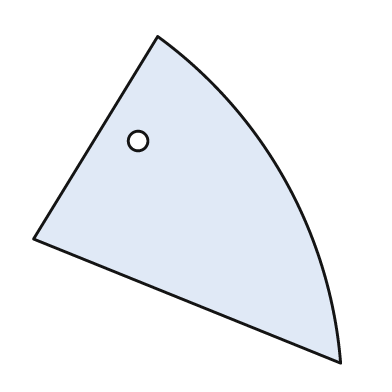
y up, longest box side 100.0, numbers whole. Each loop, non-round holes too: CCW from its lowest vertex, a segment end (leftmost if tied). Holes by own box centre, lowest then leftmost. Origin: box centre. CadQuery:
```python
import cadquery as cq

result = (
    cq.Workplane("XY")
    .moveTo(47.0, -50.0)
    .threePointArc((30.0, 6.0), (-9.0, 50.0))
    .lineTo(-47.0, -12.0)
    .close()
    .moveTo(-15.0, 18.0)
    .circle(3.0)
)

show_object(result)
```